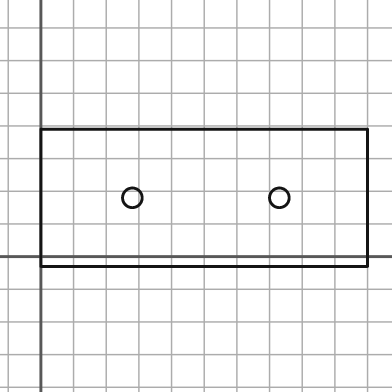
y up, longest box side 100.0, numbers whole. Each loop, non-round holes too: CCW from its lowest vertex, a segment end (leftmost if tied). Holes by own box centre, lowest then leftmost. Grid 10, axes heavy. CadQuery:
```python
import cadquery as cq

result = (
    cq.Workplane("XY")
    .moveTo(0.0, -3.0)
    .lineTo(100.0, -3.0)
    .lineTo(100.0, 39.0)
    .lineTo(0.0, 39.0)
    .close()
    .moveTo(28.0, 18.0)
    .circle(3.0)
    .moveTo(73.0, 18.0)
    .circle(3.0)
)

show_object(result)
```